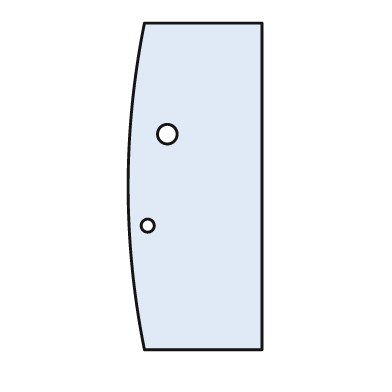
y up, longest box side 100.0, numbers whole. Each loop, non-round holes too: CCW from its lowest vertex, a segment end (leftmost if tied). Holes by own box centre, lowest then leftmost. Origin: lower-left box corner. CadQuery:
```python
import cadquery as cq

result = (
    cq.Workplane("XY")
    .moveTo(5.0, 0.0)
    .lineTo(41.0, 0.0)
    .lineTo(41.0, 100.0)
    .lineTo(5.0, 100.0)
    .threePointArc((0.0, 50.0), (5.0, 0.0))
    .close()
    .moveTo(6.0, 38.0)
    .circle(2.0)
    .moveTo(12.0, 66.0)
    .circle(3.0)
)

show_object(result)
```